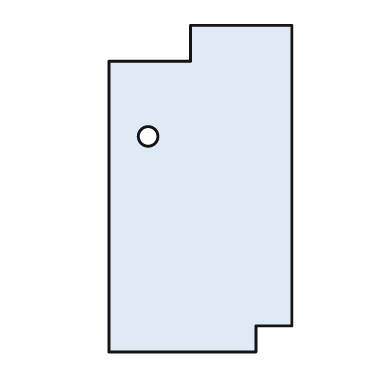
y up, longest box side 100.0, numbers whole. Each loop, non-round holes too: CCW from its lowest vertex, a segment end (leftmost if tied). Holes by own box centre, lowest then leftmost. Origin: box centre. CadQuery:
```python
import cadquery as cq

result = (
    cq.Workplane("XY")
    .moveTo(-28.0, -50.0)
    .lineTo(17.0, -50.0)
    .lineTo(17.0, -42.0)
    .lineTo(28.0, -42.0)
    .lineTo(28.0, 50.0)
    .lineTo(-3.0, 50.0)
    .lineTo(-3.0, 39.0)
    .lineTo(-28.0, 39.0)
    .close()
    .moveTo(-16.0, 16.0)
    .circle(3.0)
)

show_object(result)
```